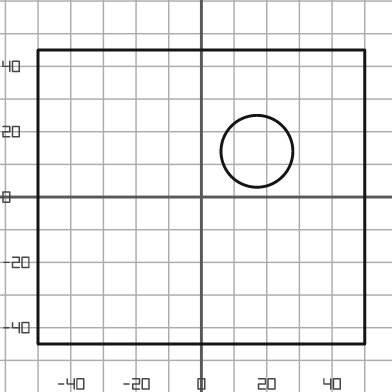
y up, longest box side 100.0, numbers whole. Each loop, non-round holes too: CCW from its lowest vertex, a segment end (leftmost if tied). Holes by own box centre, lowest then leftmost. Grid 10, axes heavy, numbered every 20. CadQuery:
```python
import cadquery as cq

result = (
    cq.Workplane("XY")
    .moveTo(-50.0, -45.0)
    .lineTo(50.0, -45.0)
    .lineTo(50.0, 45.0)
    .lineTo(-50.0, 45.0)
    .close()
    .moveTo(17.0, 14.0)
    .circle(11.0)
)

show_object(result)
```